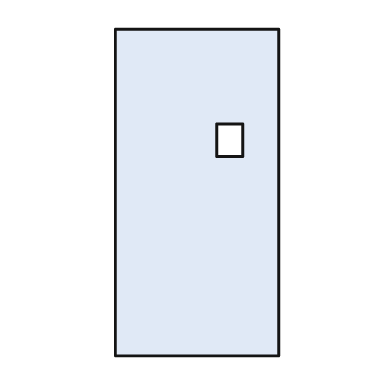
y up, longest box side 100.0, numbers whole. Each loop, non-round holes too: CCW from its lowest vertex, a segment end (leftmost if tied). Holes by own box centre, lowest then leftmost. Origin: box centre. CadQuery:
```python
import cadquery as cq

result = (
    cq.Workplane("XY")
    .moveTo(-25.0, -50.0)
    .lineTo(25.0, -50.0)
    .lineTo(25.0, 50.0)
    .lineTo(-25.0, 50.0)
    .close()
    .moveTo(6.0, 11.0)
    .lineTo(14.0, 11.0)
    .lineTo(14.0, 21.0)
    .lineTo(6.0, 21.0)
    .close()
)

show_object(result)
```